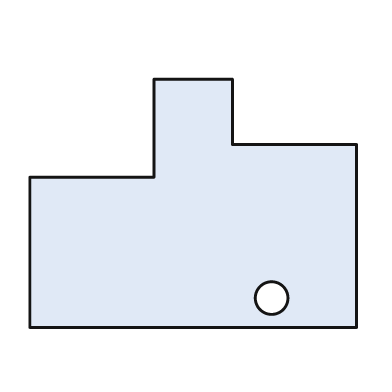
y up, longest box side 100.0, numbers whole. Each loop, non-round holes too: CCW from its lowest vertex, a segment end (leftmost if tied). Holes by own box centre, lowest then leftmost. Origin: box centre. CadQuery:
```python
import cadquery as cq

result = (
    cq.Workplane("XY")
    .moveTo(-50.0, -38.0)
    .lineTo(50.0, -38.0)
    .lineTo(50.0, 18.0)
    .lineTo(12.0, 18.0)
    .lineTo(12.0, 38.0)
    .lineTo(-12.0, 38.0)
    .lineTo(-12.0, 8.0)
    .lineTo(-50.0, 8.0)
    .close()
    .moveTo(24.0, -29.0)
    .circle(5.0)
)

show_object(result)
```